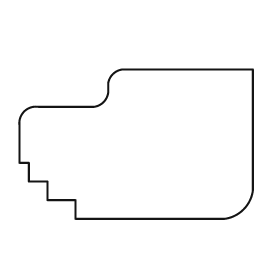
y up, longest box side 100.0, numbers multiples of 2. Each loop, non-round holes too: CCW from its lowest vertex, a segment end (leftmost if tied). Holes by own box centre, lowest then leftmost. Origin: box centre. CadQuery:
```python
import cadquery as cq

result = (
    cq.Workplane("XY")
    .moveTo(-26.0, -32.0)
    .lineTo(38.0, -32.0)
    .threePointArc((46.0, -28.0), (50.0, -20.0))
    .lineTo(50.0, 32.0)
    .lineTo(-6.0, 32.0)
    .threePointArc((-10.0, 30.0), (-12.0, 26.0))
    .lineTo(-12.0, 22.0)
    .threePointArc((-14.0, 18.0), (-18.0, 16.0))
    .lineTo(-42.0, 16.0)
    .threePointArc((-48.0, 14.0), (-50.0, 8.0))
    .lineTo(-50.0, -8.0)
    .lineTo(-46.0, -8.0)
    .lineTo(-46.0, -16.0)
    .lineTo(-38.0, -16.0)
    .lineTo(-38.0, -24.0)
    .lineTo(-26.0, -24.0)
    .close()
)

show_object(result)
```